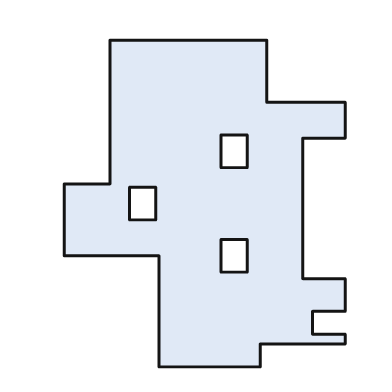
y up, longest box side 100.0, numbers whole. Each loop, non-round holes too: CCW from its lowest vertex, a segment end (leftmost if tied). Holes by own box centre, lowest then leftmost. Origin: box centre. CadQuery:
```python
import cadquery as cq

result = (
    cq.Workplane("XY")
    .moveTo(-14.0, -50.0)
    .lineTo(17.0, -50.0)
    .lineTo(17.0, -43.0)
    .lineTo(43.0, -43.0)
    .lineTo(43.0, -40.0)
    .lineTo(33.0, -40.0)
    .lineTo(33.0, -33.0)
    .lineTo(43.0, -33.0)
    .lineTo(43.0, -23.0)
    .lineTo(30.0, -23.0)
    .lineTo(30.0, 20.0)
    .lineTo(43.0, 20.0)
    .lineTo(43.0, 31.0)
    .lineTo(19.0, 31.0)
    .lineTo(19.0, 50.0)
    .lineTo(-29.0, 50.0)
    .lineTo(-29.0, 6.0)
    .lineTo(-43.0, 6.0)
    .lineTo(-43.0, -16.0)
    .lineTo(-14.0, -16.0)
    .close()
    .moveTo(5.0, -21.0)
    .lineTo(13.0, -21.0)
    .lineTo(13.0, -11.0)
    .lineTo(5.0, -11.0)
    .close()
    .moveTo(-23.0, -5.0)
    .lineTo(-15.0, -5.0)
    .lineTo(-15.0, 5.0)
    .lineTo(-23.0, 5.0)
    .close()
    .moveTo(5.0, 11.0)
    .lineTo(13.0, 11.0)
    .lineTo(13.0, 21.0)
    .lineTo(5.0, 21.0)
    .close()
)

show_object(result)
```